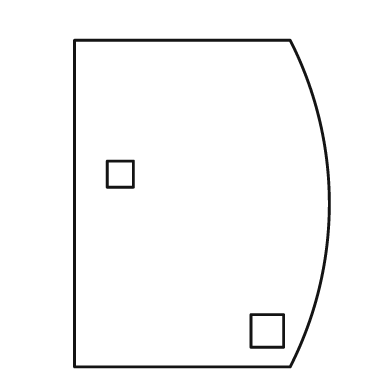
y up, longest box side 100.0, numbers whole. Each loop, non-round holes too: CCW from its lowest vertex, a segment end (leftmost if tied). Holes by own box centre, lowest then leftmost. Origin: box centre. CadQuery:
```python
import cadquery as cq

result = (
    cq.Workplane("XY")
    .moveTo(-39.0, -50.0)
    .lineTo(27.0, -50.0)
    .threePointArc((39.0, 0.0), (27.0, 50.0))
    .lineTo(-39.0, 50.0)
    .close()
    .moveTo(15.0, -44.0)
    .lineTo(25.0, -44.0)
    .lineTo(25.0, -34.0)
    .lineTo(15.0, -34.0)
    .close()
    .moveTo(-29.0, 5.0)
    .lineTo(-21.0, 5.0)
    .lineTo(-21.0, 13.0)
    .lineTo(-29.0, 13.0)
    .close()
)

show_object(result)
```